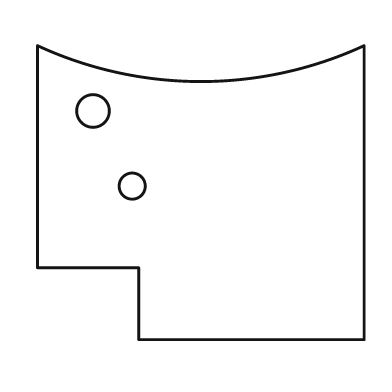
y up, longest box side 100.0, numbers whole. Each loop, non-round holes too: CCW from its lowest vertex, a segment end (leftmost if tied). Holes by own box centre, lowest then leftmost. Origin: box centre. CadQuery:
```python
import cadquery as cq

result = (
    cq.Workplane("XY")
    .moveTo(-19.0, -45.0)
    .lineTo(50.0, -45.0)
    .lineTo(50.0, 45.0)
    .threePointArc((0.0, 34.0), (-50.0, 45.0))
    .lineTo(-50.0, -23.0)
    .lineTo(-19.0, -23.0)
    .close()
    .moveTo(-21.0, 2.0)
    .circle(4.0)
    .moveTo(-33.0, 25.0)
    .circle(5.0)
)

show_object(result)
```